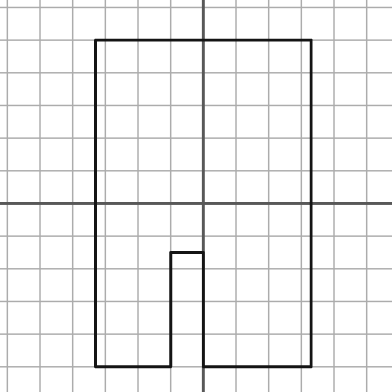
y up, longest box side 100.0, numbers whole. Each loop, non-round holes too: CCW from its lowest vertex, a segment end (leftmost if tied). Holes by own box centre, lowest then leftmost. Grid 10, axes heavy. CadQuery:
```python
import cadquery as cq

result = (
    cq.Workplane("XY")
    .moveTo(-33.0, -50.0)
    .lineTo(-10.0, -50.0)
    .lineTo(-10.0, -15.0)
    .lineTo(0.0, -15.0)
    .lineTo(0.0, -50.0)
    .lineTo(33.0, -50.0)
    .lineTo(33.0, 50.0)
    .lineTo(-33.0, 50.0)
    .close()
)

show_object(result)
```